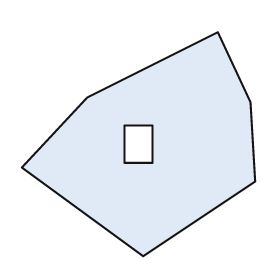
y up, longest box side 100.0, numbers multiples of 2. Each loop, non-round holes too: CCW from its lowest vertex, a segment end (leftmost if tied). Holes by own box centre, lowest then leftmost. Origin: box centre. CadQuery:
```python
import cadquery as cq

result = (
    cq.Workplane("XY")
    .moveTo(2.0, -48.0)
    .lineTo(50.0, -16.0)
    .lineTo(48.0, 18.0)
    .lineTo(34.0, 48.0)
    .lineTo(-22.0, 20.0)
    .lineTo(-50.0, -10.0)
    .close()
    .moveTo(-6.0, -8.0)
    .lineTo(6.0, -8.0)
    .lineTo(6.0, 8.0)
    .lineTo(-6.0, 8.0)
    .close()
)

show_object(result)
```